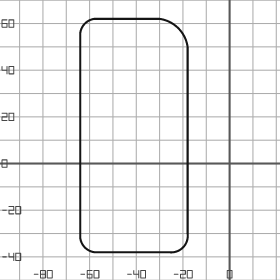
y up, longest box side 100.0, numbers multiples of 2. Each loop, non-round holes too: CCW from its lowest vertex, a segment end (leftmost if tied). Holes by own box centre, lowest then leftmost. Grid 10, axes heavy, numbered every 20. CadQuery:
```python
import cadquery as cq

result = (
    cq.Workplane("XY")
    .moveTo(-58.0, -38.0)
    .lineTo(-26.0, -38.0)
    .threePointArc((-20.0, -36.0), (-18.0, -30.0))
    .lineTo(-18.0, 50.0)
    .threePointArc((-22.0, 58.0), (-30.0, 62.0))
    .lineTo(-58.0, 62.0)
    .threePointArc((-62.0, 60.0), (-64.0, 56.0))
    .lineTo(-64.0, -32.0)
    .threePointArc((-62.0, -36.0), (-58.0, -38.0))
    .close()
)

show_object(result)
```